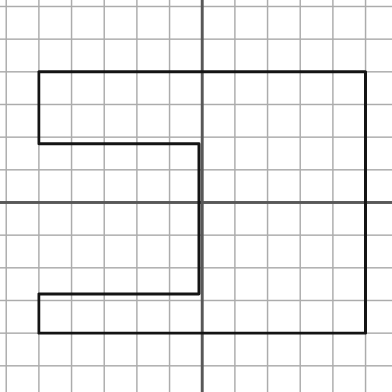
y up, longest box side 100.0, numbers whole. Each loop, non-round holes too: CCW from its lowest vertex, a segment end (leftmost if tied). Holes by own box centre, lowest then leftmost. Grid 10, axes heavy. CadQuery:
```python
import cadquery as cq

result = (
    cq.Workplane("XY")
    .moveTo(-50.0, -40.0)
    .lineTo(50.0, -40.0)
    .lineTo(50.0, 40.0)
    .lineTo(-50.0, 40.0)
    .lineTo(-50.0, 18.0)
    .lineTo(-1.0, 18.0)
    .lineTo(-1.0, -28.0)
    .lineTo(-50.0, -28.0)
    .close()
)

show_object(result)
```